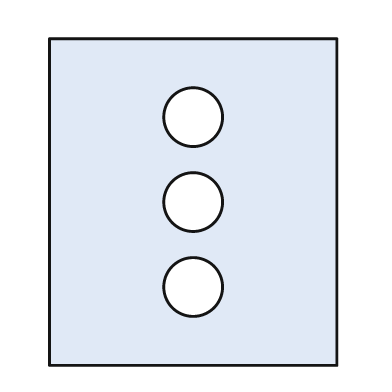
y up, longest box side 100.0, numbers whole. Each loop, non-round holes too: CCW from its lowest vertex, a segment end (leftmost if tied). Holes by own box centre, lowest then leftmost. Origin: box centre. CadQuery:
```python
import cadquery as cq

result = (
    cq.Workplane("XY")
    .moveTo(-44.0, -50.0)
    .lineTo(44.0, -50.0)
    .lineTo(44.0, 50.0)
    .lineTo(-44.0, 50.0)
    .close()
    .moveTo(0.0, -26.0)
    .circle(9.0)
    .moveTo(0.0, 0.0)
    .circle(9.0)
    .moveTo(0.0, 26.0)
    .circle(9.0)
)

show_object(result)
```